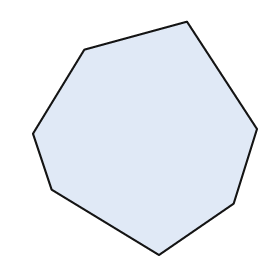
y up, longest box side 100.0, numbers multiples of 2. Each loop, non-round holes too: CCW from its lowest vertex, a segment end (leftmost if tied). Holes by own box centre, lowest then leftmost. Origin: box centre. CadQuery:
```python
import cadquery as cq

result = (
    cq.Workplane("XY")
    .moveTo(6.0, -50.0)
    .lineTo(38.0, -28.0)
    .lineTo(48.0, 4.0)
    .lineTo(18.0, 50.0)
    .lineTo(-26.0, 38.0)
    .lineTo(-48.0, 2.0)
    .lineTo(-40.0, -22.0)
    .close()
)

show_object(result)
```